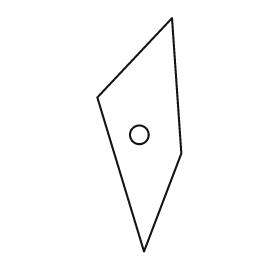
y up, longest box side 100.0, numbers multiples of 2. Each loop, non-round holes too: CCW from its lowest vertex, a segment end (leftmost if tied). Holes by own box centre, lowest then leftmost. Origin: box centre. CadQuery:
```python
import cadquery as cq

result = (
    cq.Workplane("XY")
    .moveTo(2.0, -50.0)
    .lineTo(18.0, -8.0)
    .lineTo(14.0, 50.0)
    .lineTo(-18.0, 16.0)
    .close()
    .moveTo(0.0, 0.0)
    .circle(4.0)
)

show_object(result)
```